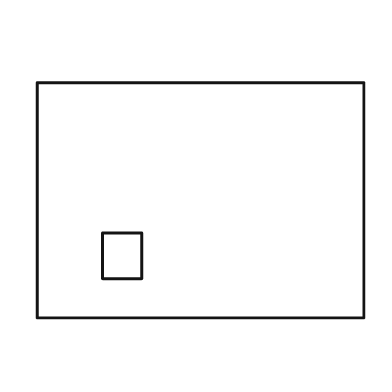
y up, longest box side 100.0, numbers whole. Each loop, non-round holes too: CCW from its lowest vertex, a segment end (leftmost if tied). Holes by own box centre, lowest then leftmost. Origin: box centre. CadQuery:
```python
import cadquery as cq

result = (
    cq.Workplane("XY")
    .moveTo(-50.0, -36.0)
    .lineTo(50.0, -36.0)
    .lineTo(50.0, 36.0)
    .lineTo(-50.0, 36.0)
    .close()
    .moveTo(-30.0, -24.0)
    .lineTo(-18.0, -24.0)
    .lineTo(-18.0, -10.0)
    .lineTo(-30.0, -10.0)
    .close()
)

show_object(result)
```